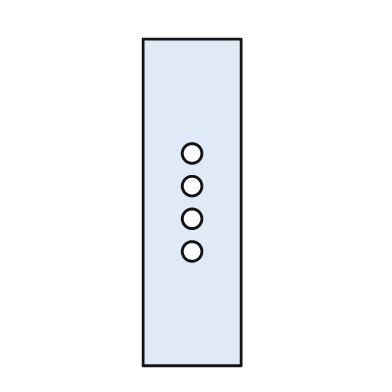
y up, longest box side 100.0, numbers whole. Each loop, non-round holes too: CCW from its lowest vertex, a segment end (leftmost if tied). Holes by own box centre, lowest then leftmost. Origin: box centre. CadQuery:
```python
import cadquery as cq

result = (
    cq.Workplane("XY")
    .moveTo(-15.0, -50.0)
    .lineTo(15.0, -50.0)
    .lineTo(15.0, 50.0)
    .lineTo(-15.0, 50.0)
    .close()
    .moveTo(0.0, -15.0)
    .circle(3.0)
    .moveTo(0.0, -5.0)
    .circle(3.0)
    .moveTo(0.0, 5.0)
    .circle(3.0)
    .moveTo(0.0, 15.0)
    .circle(3.0)
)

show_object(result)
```